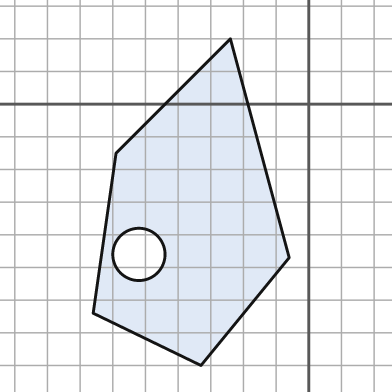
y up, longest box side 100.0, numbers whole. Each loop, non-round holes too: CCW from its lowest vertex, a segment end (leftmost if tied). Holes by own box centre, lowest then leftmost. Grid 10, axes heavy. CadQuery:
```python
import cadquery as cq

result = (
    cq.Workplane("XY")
    .moveTo(-33.0, -80.0)
    .lineTo(-6.0, -47.0)
    .lineTo(-24.0, 20.0)
    .lineTo(-59.0, -15.0)
    .lineTo(-66.0, -64.0)
    .close()
    .moveTo(-52.0, -46.0)
    .circle(8.0)
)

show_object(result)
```